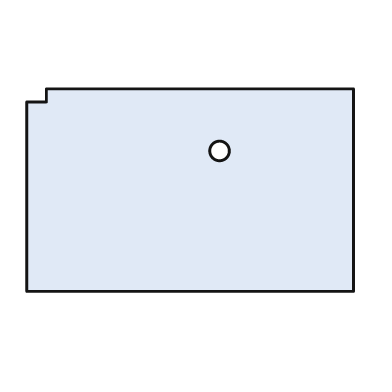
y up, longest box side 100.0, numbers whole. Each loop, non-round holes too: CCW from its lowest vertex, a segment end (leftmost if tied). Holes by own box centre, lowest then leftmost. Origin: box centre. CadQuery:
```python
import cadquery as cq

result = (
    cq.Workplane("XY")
    .moveTo(-50.0, -31.0)
    .lineTo(50.0, -31.0)
    .lineTo(50.0, 31.0)
    .lineTo(-44.0, 31.0)
    .lineTo(-44.0, 27.0)
    .lineTo(-50.0, 27.0)
    .close()
    .moveTo(9.0, 12.0)
    .circle(3.0)
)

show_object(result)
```